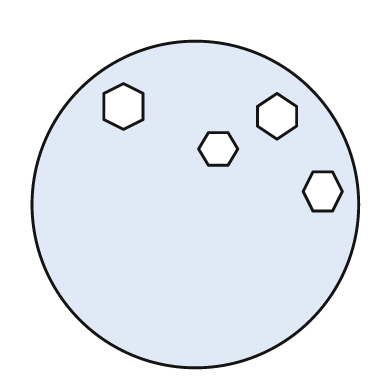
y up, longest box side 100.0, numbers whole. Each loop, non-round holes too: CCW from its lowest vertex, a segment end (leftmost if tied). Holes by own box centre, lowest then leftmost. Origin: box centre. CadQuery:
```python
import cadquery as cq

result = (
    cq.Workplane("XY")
    .moveTo(0.0, 0.0)
    .circle(50.0)
    .moveTo(36.0, -2.0)
    .lineTo(42.0, -2.0)
    .lineTo(45.0, 4.0)
    .lineTo(42.0, 10.0)
    .lineTo(36.0, 10.0)
    .lineTo(33.0, 4.0)
    .close()
    .moveTo(4.0, 12.0)
    .lineTo(10.0, 12.0)
    .lineTo(13.0, 17.0)
    .lineTo(10.0, 22.0)
    .lineTo(4.0, 22.0)
    .lineTo(1.0, 17.0)
    .close()
    .moveTo(25.0, 20.0)
    .lineTo(31.0, 24.0)
    .lineTo(31.0, 30.0)
    .lineTo(25.0, 34.0)
    .lineTo(19.0, 30.0)
    .lineTo(19.0, 24.0)
    .close()
    .moveTo(-22.0, 23.0)
    .lineTo(-16.0, 26.0)
    .lineTo(-16.0, 34.0)
    .lineTo(-22.0, 37.0)
    .lineTo(-28.0, 34.0)
    .lineTo(-28.0, 26.0)
    .close()
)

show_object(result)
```